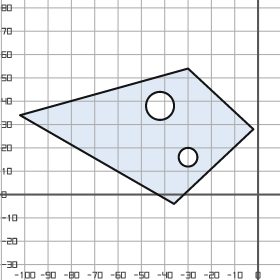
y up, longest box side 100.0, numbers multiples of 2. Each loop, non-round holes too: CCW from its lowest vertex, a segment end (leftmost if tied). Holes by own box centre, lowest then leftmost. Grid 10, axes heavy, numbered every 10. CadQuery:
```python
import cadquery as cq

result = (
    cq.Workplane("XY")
    .moveTo(-36.0, -4.0)
    .lineTo(-2.0, 28.0)
    .lineTo(-30.0, 54.0)
    .lineTo(-102.0, 34.0)
    .close()
    .moveTo(-30.0, 16.0)
    .circle(4.0)
    .moveTo(-42.0, 38.0)
    .circle(6.0)
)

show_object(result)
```